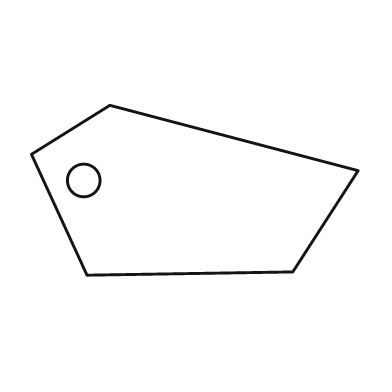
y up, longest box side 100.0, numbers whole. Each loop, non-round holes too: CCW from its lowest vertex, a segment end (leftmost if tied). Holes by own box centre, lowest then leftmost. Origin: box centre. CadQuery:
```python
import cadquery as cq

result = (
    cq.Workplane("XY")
    .moveTo(-33.0, -26.0)
    .lineTo(30.0, -25.0)
    .lineTo(50.0, 6.0)
    .lineTo(-26.0, 26.0)
    .lineTo(-50.0, 11.0)
    .close()
    .moveTo(-34.0, 3.0)
    .circle(5.0)
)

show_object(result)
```